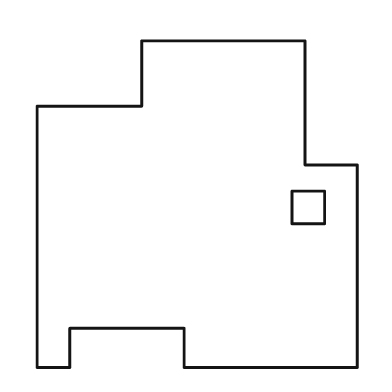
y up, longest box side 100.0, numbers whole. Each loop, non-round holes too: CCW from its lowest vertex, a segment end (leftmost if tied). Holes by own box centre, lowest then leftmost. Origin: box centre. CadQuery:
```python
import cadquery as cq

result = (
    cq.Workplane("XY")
    .moveTo(-49.0, -50.0)
    .lineTo(-39.0, -50.0)
    .lineTo(-39.0, -38.0)
    .lineTo(-4.0, -38.0)
    .lineTo(-4.0, -50.0)
    .lineTo(49.0, -50.0)
    .lineTo(49.0, 12.0)
    .lineTo(33.0, 12.0)
    .lineTo(33.0, 50.0)
    .lineTo(-17.0, 50.0)
    .lineTo(-17.0, 30.0)
    .lineTo(-49.0, 30.0)
    .close()
    .moveTo(29.0, -6.0)
    .lineTo(39.0, -6.0)
    .lineTo(39.0, 4.0)
    .lineTo(29.0, 4.0)
    .close()
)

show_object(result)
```